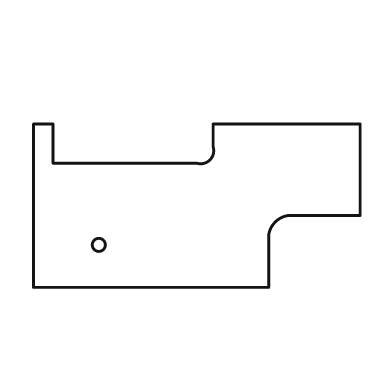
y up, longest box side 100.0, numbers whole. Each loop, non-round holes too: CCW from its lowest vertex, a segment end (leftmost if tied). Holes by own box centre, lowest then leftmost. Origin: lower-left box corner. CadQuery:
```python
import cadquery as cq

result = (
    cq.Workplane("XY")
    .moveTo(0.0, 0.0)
    .lineTo(72.0, 0.0)
    .lineTo(72.0, 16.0)
    .threePointArc((74.0, 20.0), (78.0, 22.0))
    .lineTo(100.0, 22.0)
    .lineTo(100.0, 50.0)
    .lineTo(55.0, 50.0)
    .lineTo(55.0, 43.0)
    .threePointArc((54.0, 39.0), (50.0, 38.0))
    .lineTo(6.0, 38.0)
    .lineTo(6.0, 50.0)
    .lineTo(0.0, 50.0)
    .close()
    .moveTo(20.0, 13.0)
    .circle(2.0)
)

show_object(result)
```